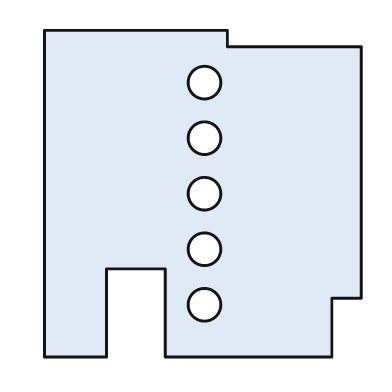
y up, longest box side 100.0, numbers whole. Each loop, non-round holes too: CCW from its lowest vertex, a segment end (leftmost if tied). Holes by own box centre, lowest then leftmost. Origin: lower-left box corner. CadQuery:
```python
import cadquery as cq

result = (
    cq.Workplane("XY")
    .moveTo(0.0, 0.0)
    .lineTo(19.0, 0.0)
    .lineTo(19.0, 27.0)
    .lineTo(37.0, 27.0)
    .lineTo(37.0, 0.0)
    .lineTo(88.0, 0.0)
    .lineTo(88.0, 18.0)
    .lineTo(97.0, 18.0)
    .lineTo(97.0, 95.0)
    .lineTo(56.0, 95.0)
    .lineTo(56.0, 100.0)
    .lineTo(0.0, 100.0)
    .close()
    .moveTo(49.0, 16.0)
    .circle(5.0)
    .moveTo(49.0, 33.0)
    .circle(5.0)
    .moveTo(49.0, 50.0)
    .circle(5.0)
    .moveTo(49.0, 67.0)
    .circle(5.0)
    .moveTo(49.0, 84.0)
    .circle(5.0)
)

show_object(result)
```